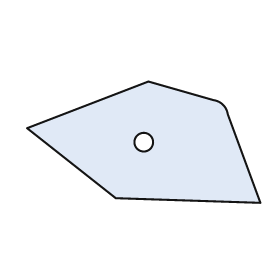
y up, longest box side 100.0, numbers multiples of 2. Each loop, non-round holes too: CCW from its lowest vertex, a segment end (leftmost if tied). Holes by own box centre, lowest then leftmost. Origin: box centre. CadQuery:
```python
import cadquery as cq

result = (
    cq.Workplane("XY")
    .moveTo(50.0, -26.0)
    .lineTo(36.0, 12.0)
    .threePointArc((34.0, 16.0), (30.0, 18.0))
    .lineTo(2.0, 26.0)
    .lineTo(-50.0, 6.0)
    .lineTo(-12.0, -24.0)
    .close()
    .moveTo(0.0, 0.0)
    .circle(4.0)
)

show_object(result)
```